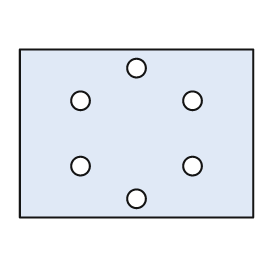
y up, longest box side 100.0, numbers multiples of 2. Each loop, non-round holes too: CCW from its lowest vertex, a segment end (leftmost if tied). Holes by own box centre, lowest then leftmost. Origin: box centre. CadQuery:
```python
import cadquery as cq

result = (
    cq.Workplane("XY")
    .moveTo(-50.0, -36.0)
    .lineTo(50.0, -36.0)
    .lineTo(50.0, 36.0)
    .lineTo(-50.0, 36.0)
    .close()
    .moveTo(0.0, -28.0)
    .circle(4.0)
    .moveTo(-24.0, -14.0)
    .circle(4.0)
    .moveTo(24.0, -14.0)
    .circle(4.0)
    .moveTo(-24.0, 14.0)
    .circle(4.0)
    .moveTo(24.0, 14.0)
    .circle(4.0)
    .moveTo(0.0, 28.0)
    .circle(4.0)
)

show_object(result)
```